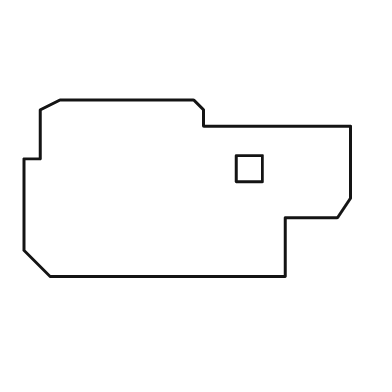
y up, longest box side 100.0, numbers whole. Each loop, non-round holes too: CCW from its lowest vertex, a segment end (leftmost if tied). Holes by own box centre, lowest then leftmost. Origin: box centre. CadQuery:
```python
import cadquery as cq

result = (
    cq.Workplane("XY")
    .moveTo(-42.0, -27.0)
    .lineTo(30.0, -27.0)
    .lineTo(30.0, -9.0)
    .lineTo(46.0, -9.0)
    .lineTo(50.0, -3.0)
    .lineTo(50.0, 19.0)
    .lineTo(5.0, 19.0)
    .lineTo(5.0, 24.0)
    .lineTo(2.0, 27.0)
    .lineTo(-39.0, 27.0)
    .lineTo(-45.0, 24.0)
    .lineTo(-45.0, 9.0)
    .lineTo(-50.0, 9.0)
    .lineTo(-50.0, -19.0)
    .close()
    .moveTo(15.0, 2.0)
    .lineTo(23.0, 2.0)
    .lineTo(23.0, 10.0)
    .lineTo(15.0, 10.0)
    .close()
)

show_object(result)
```